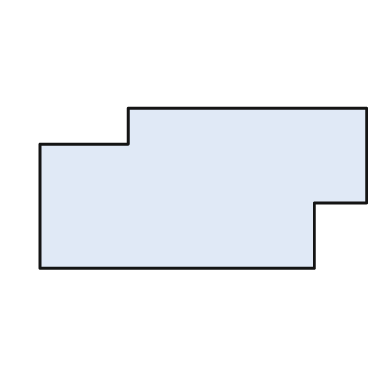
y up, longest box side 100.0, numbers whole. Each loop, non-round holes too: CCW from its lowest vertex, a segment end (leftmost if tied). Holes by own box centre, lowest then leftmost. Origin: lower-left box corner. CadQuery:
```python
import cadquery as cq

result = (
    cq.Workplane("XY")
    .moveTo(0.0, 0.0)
    .lineTo(84.0, 0.0)
    .lineTo(84.0, 20.0)
    .lineTo(100.0, 20.0)
    .lineTo(100.0, 49.0)
    .lineTo(27.0, 49.0)
    .lineTo(27.0, 38.0)
    .lineTo(0.0, 38.0)
    .close()
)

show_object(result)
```